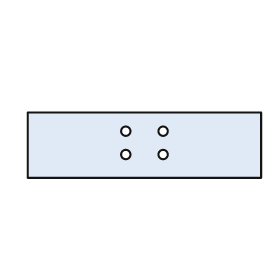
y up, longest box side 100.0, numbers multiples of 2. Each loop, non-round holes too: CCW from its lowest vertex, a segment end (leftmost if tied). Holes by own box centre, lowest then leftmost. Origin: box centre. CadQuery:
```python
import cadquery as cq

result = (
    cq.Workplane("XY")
    .moveTo(-50.0, -14.0)
    .lineTo(50.0, -14.0)
    .lineTo(50.0, 14.0)
    .lineTo(-50.0, 14.0)
    .close()
    .moveTo(-8.0, -4.0)
    .circle(2.0)
    .moveTo(8.0, -4.0)
    .circle(2.0)
    .moveTo(-8.0, 6.0)
    .circle(2.0)
    .moveTo(8.0, 6.0)
    .circle(2.0)
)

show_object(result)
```